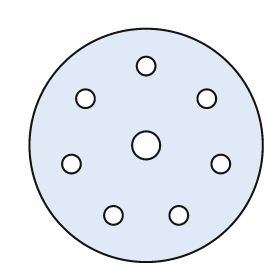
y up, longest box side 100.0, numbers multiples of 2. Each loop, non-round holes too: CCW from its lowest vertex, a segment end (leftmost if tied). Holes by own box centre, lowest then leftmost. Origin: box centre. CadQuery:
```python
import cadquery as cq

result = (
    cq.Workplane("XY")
    .moveTo(0.0, 0.0)
    .circle(50.0)
    .moveTo(-14.0, -30.0)
    .circle(4.0)
    .moveTo(14.0, -30.0)
    .circle(4.0)
    .moveTo(-32.0, -8.0)
    .circle(4.0)
    .moveTo(32.0, -8.0)
    .circle(4.0)
    .moveTo(0.0, 0.0)
    .circle(6.0)
    .moveTo(-26.0, 20.0)
    .circle(4.0)
    .moveTo(26.0, 20.0)
    .circle(4.0)
    .moveTo(0.0, 34.0)
    .circle(4.0)
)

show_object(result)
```